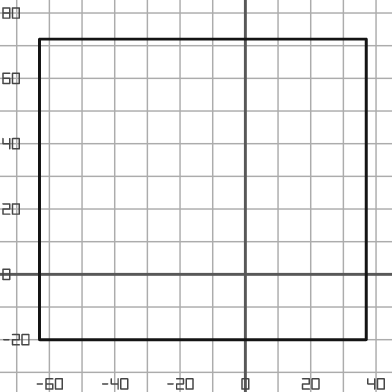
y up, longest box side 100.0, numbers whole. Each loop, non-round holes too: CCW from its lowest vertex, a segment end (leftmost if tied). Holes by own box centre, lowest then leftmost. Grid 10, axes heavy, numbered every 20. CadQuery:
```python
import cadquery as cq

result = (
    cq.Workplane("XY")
    .moveTo(-63.0, -20.0)
    .lineTo(37.0, -20.0)
    .lineTo(37.0, 72.0)
    .lineTo(-63.0, 72.0)
    .close()
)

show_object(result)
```